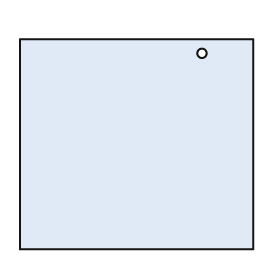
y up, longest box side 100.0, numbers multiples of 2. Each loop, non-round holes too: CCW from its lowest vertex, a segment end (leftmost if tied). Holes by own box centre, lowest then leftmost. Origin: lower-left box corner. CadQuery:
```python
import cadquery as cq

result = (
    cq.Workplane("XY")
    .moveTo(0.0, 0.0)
    .lineTo(100.0, 0.0)
    .lineTo(100.0, 90.0)
    .lineTo(0.0, 90.0)
    .close()
    .moveTo(78.0, 84.0)
    .circle(2.0)
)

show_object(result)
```